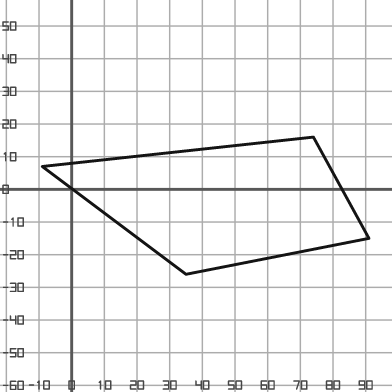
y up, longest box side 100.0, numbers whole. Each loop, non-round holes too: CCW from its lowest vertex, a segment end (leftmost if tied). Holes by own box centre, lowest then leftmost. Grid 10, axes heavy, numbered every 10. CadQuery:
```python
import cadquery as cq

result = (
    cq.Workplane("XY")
    .moveTo(35.0, -26.0)
    .lineTo(91.0, -15.0)
    .lineTo(74.0, 16.0)
    .lineTo(-9.0, 7.0)
    .close()
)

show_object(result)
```